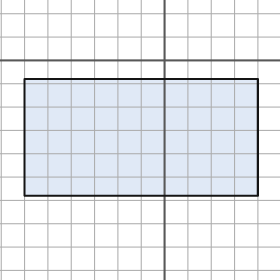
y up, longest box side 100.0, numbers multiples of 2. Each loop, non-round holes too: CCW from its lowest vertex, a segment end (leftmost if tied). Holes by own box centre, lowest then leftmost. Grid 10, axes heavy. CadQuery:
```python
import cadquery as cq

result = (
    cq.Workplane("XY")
    .moveTo(-60.0, -58.0)
    .lineTo(40.0, -58.0)
    .lineTo(40.0, -8.0)
    .lineTo(-60.0, -8.0)
    .close()
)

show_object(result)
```